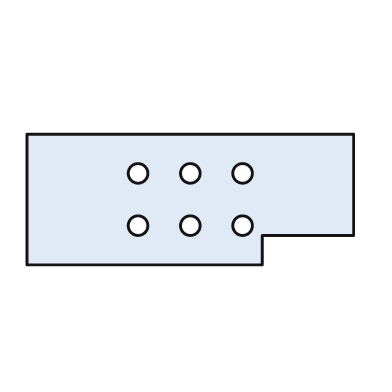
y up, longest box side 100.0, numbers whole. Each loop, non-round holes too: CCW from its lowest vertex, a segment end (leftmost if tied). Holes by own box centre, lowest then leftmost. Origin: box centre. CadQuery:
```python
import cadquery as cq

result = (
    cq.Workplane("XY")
    .moveTo(-50.0, -20.0)
    .lineTo(22.0, -20.0)
    .lineTo(22.0, -11.0)
    .lineTo(50.0, -11.0)
    .lineTo(50.0, 20.0)
    .lineTo(-50.0, 20.0)
    .close()
    .moveTo(-16.0, -8.0)
    .circle(3.0)
    .moveTo(0.0, -8.0)
    .circle(3.0)
    .moveTo(16.0, -8.0)
    .circle(3.0)
    .moveTo(-16.0, 8.0)
    .circle(3.0)
    .moveTo(0.0, 8.0)
    .circle(3.0)
    .moveTo(16.0, 8.0)
    .circle(3.0)
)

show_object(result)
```